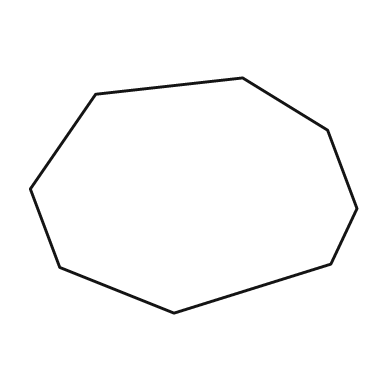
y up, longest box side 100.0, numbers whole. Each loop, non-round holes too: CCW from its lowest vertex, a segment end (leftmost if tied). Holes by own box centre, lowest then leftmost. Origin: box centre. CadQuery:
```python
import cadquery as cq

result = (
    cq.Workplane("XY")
    .moveTo(-6.0, -36.0)
    .lineTo(42.0, -21.0)
    .lineTo(50.0, -4.0)
    .lineTo(41.0, 20.0)
    .lineTo(15.0, 36.0)
    .lineTo(-30.0, 31.0)
    .lineTo(-50.0, 2.0)
    .lineTo(-41.0, -22.0)
    .close()
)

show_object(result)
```